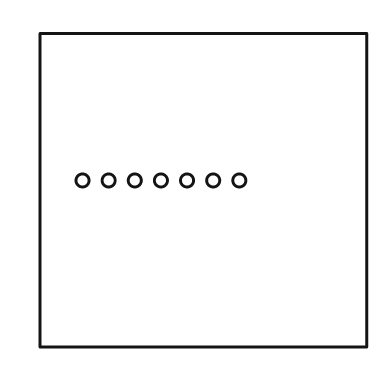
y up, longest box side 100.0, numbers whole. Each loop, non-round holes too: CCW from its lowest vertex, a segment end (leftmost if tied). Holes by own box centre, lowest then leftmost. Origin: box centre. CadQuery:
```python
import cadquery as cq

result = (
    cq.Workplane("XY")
    .moveTo(-50.0, -48.0)
    .lineTo(50.0, -48.0)
    .lineTo(50.0, 48.0)
    .lineTo(-50.0, 48.0)
    .close()
    .moveTo(-37.0, 3.0)
    .circle(2.0)
    .moveTo(-29.0, 3.0)
    .circle(2.0)
    .moveTo(-21.0, 3.0)
    .circle(2.0)
    .moveTo(-13.0, 3.0)
    .circle(2.0)
    .moveTo(-5.0, 3.0)
    .circle(2.0)
    .moveTo(3.0, 3.0)
    .circle(2.0)
    .moveTo(11.0, 3.0)
    .circle(2.0)
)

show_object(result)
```